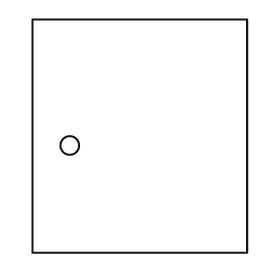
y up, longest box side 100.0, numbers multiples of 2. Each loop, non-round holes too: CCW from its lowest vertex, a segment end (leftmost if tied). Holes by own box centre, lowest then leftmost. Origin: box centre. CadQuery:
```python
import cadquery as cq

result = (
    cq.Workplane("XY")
    .moveTo(-46.0, -50.0)
    .lineTo(46.0, -50.0)
    .lineTo(46.0, 50.0)
    .lineTo(-46.0, 50.0)
    .close()
    .moveTo(-30.0, -4.0)
    .circle(4.0)
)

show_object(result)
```